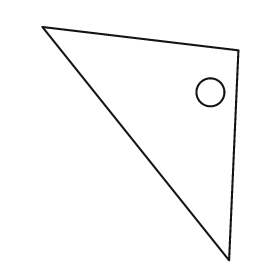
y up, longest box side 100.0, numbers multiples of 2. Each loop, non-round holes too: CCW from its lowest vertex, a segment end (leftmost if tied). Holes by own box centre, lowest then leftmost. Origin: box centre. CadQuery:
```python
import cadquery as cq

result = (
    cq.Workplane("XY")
    .moveTo(38.0, -50.0)
    .lineTo(42.0, 40.0)
    .lineTo(-42.0, 50.0)
    .close()
    .moveTo(30.0, 22.0)
    .circle(6.0)
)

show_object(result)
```